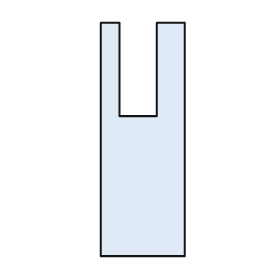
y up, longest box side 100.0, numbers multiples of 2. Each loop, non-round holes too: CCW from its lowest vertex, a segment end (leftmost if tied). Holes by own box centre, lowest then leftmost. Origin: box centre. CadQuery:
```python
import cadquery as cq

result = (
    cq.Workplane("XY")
    .moveTo(-18.0, -50.0)
    .lineTo(18.0, -50.0)
    .lineTo(18.0, 50.0)
    .lineTo(6.0, 50.0)
    .lineTo(6.0, 10.0)
    .lineTo(-10.0, 10.0)
    .lineTo(-10.0, 50.0)
    .lineTo(-18.0, 50.0)
    .close()
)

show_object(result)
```